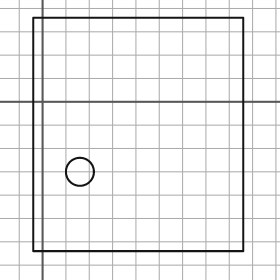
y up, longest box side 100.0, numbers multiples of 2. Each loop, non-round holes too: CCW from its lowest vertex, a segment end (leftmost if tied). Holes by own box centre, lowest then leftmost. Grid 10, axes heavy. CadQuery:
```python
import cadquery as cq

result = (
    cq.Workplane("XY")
    .moveTo(-4.0, -64.0)
    .lineTo(86.0, -64.0)
    .lineTo(86.0, 36.0)
    .lineTo(-4.0, 36.0)
    .close()
    .moveTo(16.0, -30.0)
    .circle(6.0)
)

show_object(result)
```